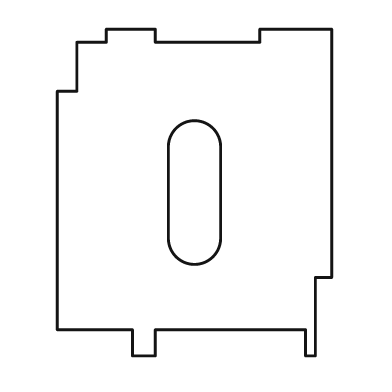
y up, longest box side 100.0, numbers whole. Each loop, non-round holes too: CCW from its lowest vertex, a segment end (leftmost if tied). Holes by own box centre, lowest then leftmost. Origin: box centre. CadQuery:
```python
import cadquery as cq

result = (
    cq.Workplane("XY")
    .moveTo(-19.0, -50.0)
    .lineTo(-12.0, -50.0)
    .lineTo(-12.0, -42.0)
    .lineTo(34.0, -42.0)
    .lineTo(34.0, -50.0)
    .lineTo(37.0, -50.0)
    .lineTo(37.0, -26.0)
    .lineTo(42.0, -26.0)
    .lineTo(42.0, 50.0)
    .lineTo(20.0, 50.0)
    .lineTo(20.0, 46.0)
    .lineTo(-12.0, 46.0)
    .lineTo(-12.0, 50.0)
    .lineTo(-27.0, 50.0)
    .lineTo(-27.0, 46.0)
    .lineTo(-36.0, 46.0)
    .lineTo(-36.0, 31.0)
    .lineTo(-42.0, 31.0)
    .lineTo(-42.0, -42.0)
    .lineTo(-19.0, -42.0)
    .close()
    .moveTo(-8.0, -14.0)
    .threePointArc((0.0, -22.0), (8.0, -14.0))
    .lineTo(8.0, 14.0)
    .threePointArc((0.0, 22.0), (-8.0, 14.0))
    .close()
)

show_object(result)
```